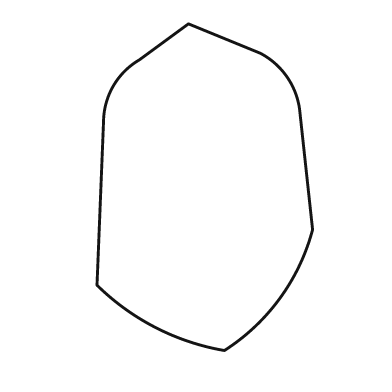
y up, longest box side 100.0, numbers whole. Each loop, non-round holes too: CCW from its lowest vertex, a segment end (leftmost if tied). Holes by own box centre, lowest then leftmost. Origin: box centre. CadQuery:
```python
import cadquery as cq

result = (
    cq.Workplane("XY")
    .moveTo(6.0, -50.0)
    .threePointArc((23.0, -34.0), (33.0, -13.0))
    .lineTo(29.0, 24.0)
    .threePointArc((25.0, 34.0), (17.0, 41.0))
    .lineTo(-5.0, 50.0)
    .lineTo(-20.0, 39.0)
    .threePointArc((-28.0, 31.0), (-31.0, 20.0))
    .lineTo(-33.0, -30.0)
    .threePointArc((-15.0, -43.0), (6.0, -50.0))
    .close()
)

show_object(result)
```